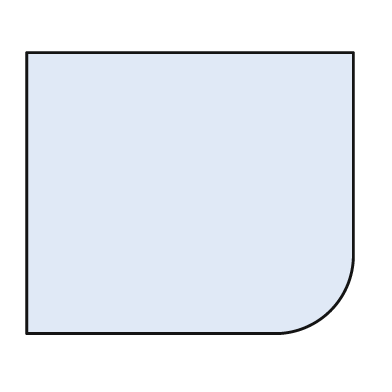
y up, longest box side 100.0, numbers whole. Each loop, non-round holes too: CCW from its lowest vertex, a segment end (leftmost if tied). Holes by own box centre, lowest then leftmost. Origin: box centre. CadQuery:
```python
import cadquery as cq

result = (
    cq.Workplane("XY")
    .moveTo(-50.0, -43.0)
    .lineTo(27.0, -43.0)
    .threePointArc((43.0, -36.0), (50.0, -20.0))
    .lineTo(50.0, 43.0)
    .lineTo(-50.0, 43.0)
    .close()
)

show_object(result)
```